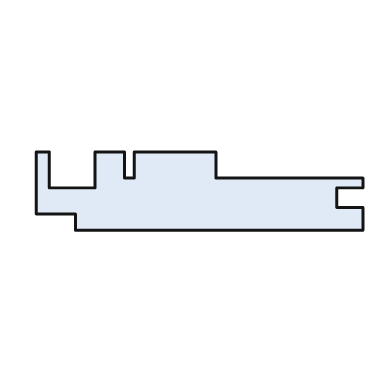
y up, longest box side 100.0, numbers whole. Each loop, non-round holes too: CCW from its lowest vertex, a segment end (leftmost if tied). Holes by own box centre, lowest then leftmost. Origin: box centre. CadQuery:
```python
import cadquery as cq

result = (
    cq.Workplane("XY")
    .moveTo(-38.0, -12.0)
    .lineTo(50.0, -12.0)
    .lineTo(50.0, -5.0)
    .lineTo(42.0, -5.0)
    .lineTo(42.0, 1.0)
    .lineTo(50.0, 1.0)
    .lineTo(50.0, 4.0)
    .lineTo(5.0, 4.0)
    .lineTo(5.0, 12.0)
    .lineTo(-20.0, 12.0)
    .lineTo(-20.0, 4.0)
    .lineTo(-23.0, 4.0)
    .lineTo(-23.0, 12.0)
    .lineTo(-32.0, 12.0)
    .lineTo(-32.0, 1.0)
    .lineTo(-46.0, 1.0)
    .lineTo(-46.0, 12.0)
    .lineTo(-50.0, 12.0)
    .lineTo(-50.0, -7.0)
    .lineTo(-38.0, -7.0)
    .close()
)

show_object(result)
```